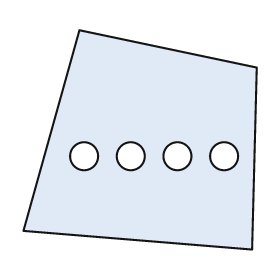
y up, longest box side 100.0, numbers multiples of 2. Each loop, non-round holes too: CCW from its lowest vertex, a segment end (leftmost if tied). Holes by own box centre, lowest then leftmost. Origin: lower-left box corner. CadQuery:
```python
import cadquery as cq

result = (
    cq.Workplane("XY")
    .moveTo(98.0, 0.0)
    .lineTo(100.0, 78.0)
    .lineTo(24.0, 94.0)
    .lineTo(0.0, 8.0)
    .close()
    .moveTo(26.0, 40.0)
    .circle(6.0)
    .moveTo(46.0, 40.0)
    .circle(6.0)
    .moveTo(66.0, 40.0)
    .circle(6.0)
    .moveTo(86.0, 40.0)
    .circle(6.0)
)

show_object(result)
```